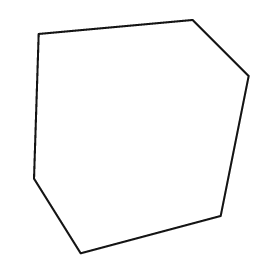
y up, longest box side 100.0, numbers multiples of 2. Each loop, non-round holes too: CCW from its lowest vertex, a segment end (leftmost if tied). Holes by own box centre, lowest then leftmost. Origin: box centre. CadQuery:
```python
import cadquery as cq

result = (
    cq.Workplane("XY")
    .moveTo(-26.0, -50.0)
    .lineTo(34.0, -34.0)
    .lineTo(46.0, 26.0)
    .lineTo(22.0, 50.0)
    .lineTo(-44.0, 44.0)
    .lineTo(-46.0, -18.0)
    .close()
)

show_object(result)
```